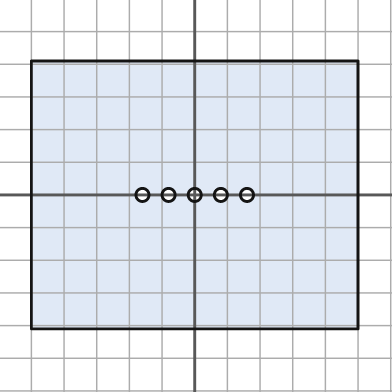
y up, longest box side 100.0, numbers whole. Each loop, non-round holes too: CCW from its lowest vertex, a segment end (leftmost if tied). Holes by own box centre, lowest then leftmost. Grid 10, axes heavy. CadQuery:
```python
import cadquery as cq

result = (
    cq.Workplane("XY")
    .moveTo(-50.0, -41.0)
    .lineTo(50.0, -41.0)
    .lineTo(50.0, 41.0)
    .lineTo(-50.0, 41.0)
    .close()
    .moveTo(-16.0, 0.0)
    .circle(2.0)
    .moveTo(-8.0, 0.0)
    .circle(2.0)
    .moveTo(0.0, 0.0)
    .circle(2.0)
    .moveTo(8.0, 0.0)
    .circle(2.0)
    .moveTo(16.0, 0.0)
    .circle(2.0)
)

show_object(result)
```